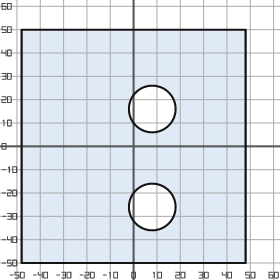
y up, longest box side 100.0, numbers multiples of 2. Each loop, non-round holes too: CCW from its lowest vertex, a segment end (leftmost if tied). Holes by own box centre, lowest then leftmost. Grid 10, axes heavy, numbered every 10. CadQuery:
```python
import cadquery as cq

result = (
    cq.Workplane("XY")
    .moveTo(-48.0, -50.0)
    .lineTo(48.0, -50.0)
    .lineTo(48.0, 50.0)
    .lineTo(-48.0, 50.0)
    .close()
    .moveTo(8.0, -26.0)
    .circle(10.0)
    .moveTo(8.0, 16.0)
    .circle(10.0)
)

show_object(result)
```